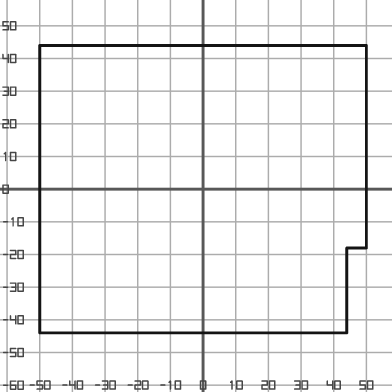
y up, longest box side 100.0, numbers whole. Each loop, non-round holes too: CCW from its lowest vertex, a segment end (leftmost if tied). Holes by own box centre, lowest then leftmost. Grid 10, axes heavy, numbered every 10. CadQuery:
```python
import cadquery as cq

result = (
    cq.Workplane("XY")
    .moveTo(-50.0, -44.0)
    .lineTo(44.0, -44.0)
    .lineTo(44.0, -18.0)
    .lineTo(50.0, -18.0)
    .lineTo(50.0, 44.0)
    .lineTo(-50.0, 44.0)
    .close()
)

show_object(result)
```